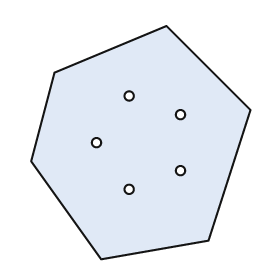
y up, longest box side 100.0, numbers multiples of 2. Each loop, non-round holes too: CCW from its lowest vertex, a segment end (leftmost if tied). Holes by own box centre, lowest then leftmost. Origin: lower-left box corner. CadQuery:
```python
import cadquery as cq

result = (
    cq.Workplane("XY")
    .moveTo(30.0, 0.0)
    .lineTo(76.0, 8.0)
    .lineTo(94.0, 64.0)
    .lineTo(58.0, 100.0)
    .lineTo(10.0, 80.0)
    .lineTo(0.0, 42.0)
    .close()
    .moveTo(42.0, 30.0)
    .circle(2.0)
    .moveTo(64.0, 38.0)
    .circle(2.0)
    .moveTo(28.0, 50.0)
    .circle(2.0)
    .moveTo(64.0, 62.0)
    .circle(2.0)
    .moveTo(42.0, 70.0)
    .circle(2.0)
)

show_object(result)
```